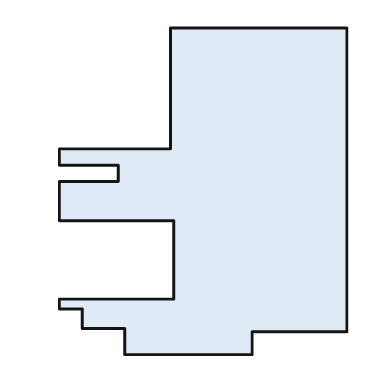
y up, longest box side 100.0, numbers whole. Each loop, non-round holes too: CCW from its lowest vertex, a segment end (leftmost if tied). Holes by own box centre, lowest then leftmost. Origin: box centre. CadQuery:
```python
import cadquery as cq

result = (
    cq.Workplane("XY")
    .moveTo(-24.0, -50.0)
    .lineTo(15.0, -50.0)
    .lineTo(15.0, -43.0)
    .lineTo(44.0, -43.0)
    .lineTo(44.0, 50.0)
    .lineTo(-10.0, 50.0)
    .lineTo(-10.0, 13.0)
    .lineTo(-44.0, 13.0)
    .lineTo(-44.0, 8.0)
    .lineTo(-26.0, 8.0)
    .lineTo(-26.0, 3.0)
    .lineTo(-44.0, 3.0)
    .lineTo(-44.0, -9.0)
    .lineTo(-9.0, -9.0)
    .lineTo(-9.0, -33.0)
    .lineTo(-44.0, -33.0)
    .lineTo(-44.0, -36.0)
    .lineTo(-37.0, -36.0)
    .lineTo(-37.0, -42.0)
    .lineTo(-24.0, -42.0)
    .close()
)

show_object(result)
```